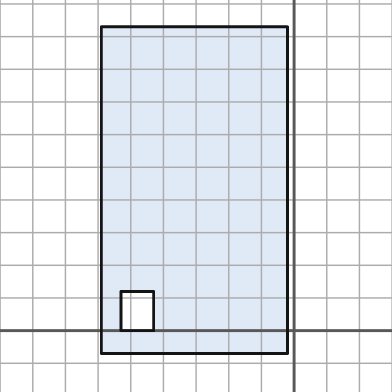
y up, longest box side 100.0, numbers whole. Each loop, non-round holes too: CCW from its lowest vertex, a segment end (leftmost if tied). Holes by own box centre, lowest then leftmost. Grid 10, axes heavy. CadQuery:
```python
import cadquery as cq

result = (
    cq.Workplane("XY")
    .moveTo(-59.0, -7.0)
    .lineTo(-2.0, -7.0)
    .lineTo(-2.0, 93.0)
    .lineTo(-59.0, 93.0)
    .close()
    .moveTo(-53.0, 0.0)
    .lineTo(-43.0, 0.0)
    .lineTo(-43.0, 12.0)
    .lineTo(-53.0, 12.0)
    .close()
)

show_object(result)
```